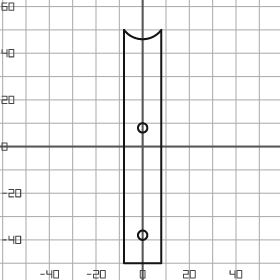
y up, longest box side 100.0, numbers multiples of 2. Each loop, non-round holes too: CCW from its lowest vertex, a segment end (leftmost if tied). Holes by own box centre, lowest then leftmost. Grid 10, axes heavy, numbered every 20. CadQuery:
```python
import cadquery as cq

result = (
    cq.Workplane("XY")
    .moveTo(-8.0, -50.0)
    .lineTo(8.0, -50.0)
    .lineTo(8.0, 50.0)
    .threePointArc((0.0, 46.0), (-8.0, 50.0))
    .close()
    .moveTo(0.0, -38.0)
    .circle(2.0)
    .moveTo(0.0, 8.0)
    .circle(2.0)
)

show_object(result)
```